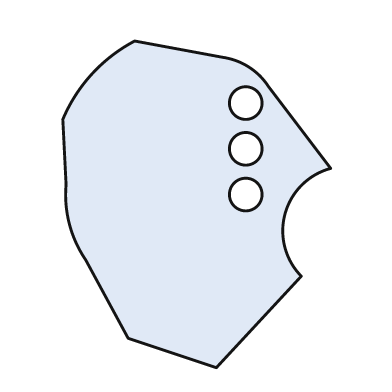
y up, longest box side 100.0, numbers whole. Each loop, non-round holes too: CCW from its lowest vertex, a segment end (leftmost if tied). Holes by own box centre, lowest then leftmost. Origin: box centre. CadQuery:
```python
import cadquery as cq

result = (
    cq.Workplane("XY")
    .moveTo(6.0, -50.0)
    .lineTo(32.0, -22.0)
    .threePointArc((27.0, -3.0), (41.0, 11.0))
    .lineTo(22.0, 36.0)
    .threePointArc((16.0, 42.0), (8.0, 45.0))
    .lineTo(-19.0, 50.0)
    .threePointArc((-32.0, 40.0), (-41.0, 26.0))
    .lineTo(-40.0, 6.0)
    .threePointArc((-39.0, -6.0), (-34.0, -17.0))
    .lineTo(-21.0, -41.0)
    .close()
    .moveTo(15.0, 3.0)
    .circle(5.0)
    .moveTo(15.0, 17.0)
    .circle(5.0)
    .moveTo(15.0, 31.0)
    .circle(5.0)
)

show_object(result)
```